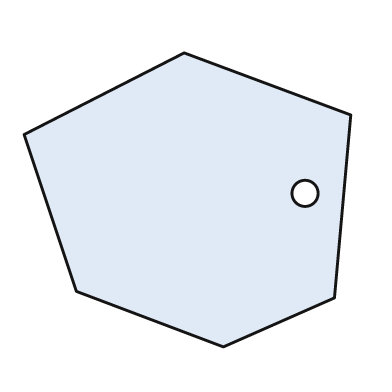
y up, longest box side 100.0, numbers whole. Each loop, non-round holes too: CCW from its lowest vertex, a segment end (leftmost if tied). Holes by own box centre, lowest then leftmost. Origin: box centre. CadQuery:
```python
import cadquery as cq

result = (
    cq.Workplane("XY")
    .moveTo(11.0, -45.0)
    .lineTo(45.0, -30.0)
    .lineTo(50.0, 26.0)
    .lineTo(-1.0, 45.0)
    .lineTo(-50.0, 20.0)
    .lineTo(-34.0, -28.0)
    .close()
    .moveTo(36.0, 2.0)
    .circle(4.0)
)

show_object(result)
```